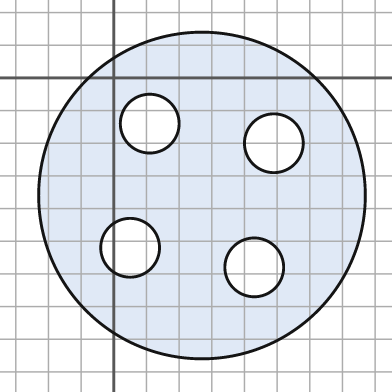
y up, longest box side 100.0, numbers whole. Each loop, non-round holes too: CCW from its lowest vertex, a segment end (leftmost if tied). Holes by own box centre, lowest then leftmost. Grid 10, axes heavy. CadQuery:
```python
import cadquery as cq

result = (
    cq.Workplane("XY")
    .moveTo(27.0, -36.0)
    .circle(50.0)
    .moveTo(43.0, -58.0)
    .circle(9.0)
    .moveTo(5.0, -52.0)
    .circle(9.0)
    .moveTo(49.0, -20.0)
    .circle(9.0)
    .moveTo(11.0, -14.0)
    .circle(9.0)
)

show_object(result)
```